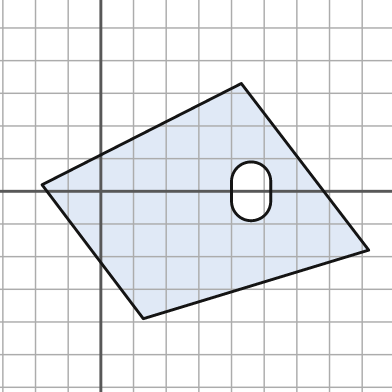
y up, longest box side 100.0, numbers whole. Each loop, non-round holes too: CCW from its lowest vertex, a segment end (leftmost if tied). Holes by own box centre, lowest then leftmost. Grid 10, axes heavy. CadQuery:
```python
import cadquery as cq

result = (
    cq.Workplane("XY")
    .moveTo(13.0, -39.0)
    .lineTo(82.0, -18.0)
    .lineTo(43.0, 33.0)
    .lineTo(-18.0, 2.0)
    .close()
    .moveTo(40.0, -3.0)
    .threePointArc((46.0, -9.0), (52.0, -3.0))
    .lineTo(52.0, 3.0)
    .threePointArc((46.0, 9.0), (40.0, 3.0))
    .close()
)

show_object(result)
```